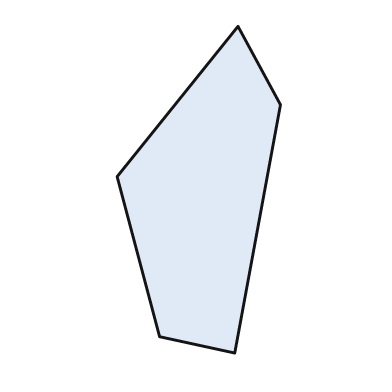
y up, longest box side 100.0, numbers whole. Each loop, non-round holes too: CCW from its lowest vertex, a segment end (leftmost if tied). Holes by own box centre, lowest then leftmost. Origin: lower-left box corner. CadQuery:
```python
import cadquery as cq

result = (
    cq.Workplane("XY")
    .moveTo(36.0, 0.0)
    .lineTo(50.0, 76.0)
    .lineTo(37.0, 100.0)
    .lineTo(0.0, 54.0)
    .lineTo(13.0, 5.0)
    .close()
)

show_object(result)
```